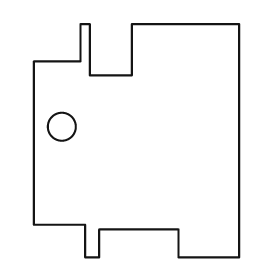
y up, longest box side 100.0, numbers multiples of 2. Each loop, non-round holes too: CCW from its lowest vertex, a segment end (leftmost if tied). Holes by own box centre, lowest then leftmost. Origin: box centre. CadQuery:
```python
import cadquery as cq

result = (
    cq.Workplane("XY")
    .moveTo(-22.0, -50.0)
    .lineTo(-16.0, -50.0)
    .lineTo(-16.0, -38.0)
    .lineTo(18.0, -38.0)
    .lineTo(18.0, -50.0)
    .lineTo(44.0, -50.0)
    .lineTo(44.0, 50.0)
    .lineTo(-2.0, 50.0)
    .lineTo(-2.0, 28.0)
    .lineTo(-20.0, 28.0)
    .lineTo(-20.0, 50.0)
    .lineTo(-24.0, 50.0)
    .lineTo(-24.0, 34.0)
    .lineTo(-44.0, 34.0)
    .lineTo(-44.0, -36.0)
    .lineTo(-22.0, -36.0)
    .close()
    .moveTo(-32.0, 6.0)
    .circle(6.0)
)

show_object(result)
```